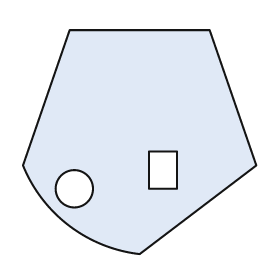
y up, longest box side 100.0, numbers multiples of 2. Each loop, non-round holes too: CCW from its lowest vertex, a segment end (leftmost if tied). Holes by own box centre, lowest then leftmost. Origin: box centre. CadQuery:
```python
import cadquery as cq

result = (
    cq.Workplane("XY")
    .moveTo(0.0, -48.0)
    .lineTo(50.0, -10.0)
    .lineTo(30.0, 48.0)
    .lineTo(-30.0, 48.0)
    .lineTo(-50.0, -10.0)
    .threePointArc((-30.0, -36.0), (0.0, -48.0))
    .close()
    .moveTo(-28.0, -20.0)
    .circle(8.0)
    .moveTo(4.0, -20.0)
    .lineTo(16.0, -20.0)
    .lineTo(16.0, -4.0)
    .lineTo(4.0, -4.0)
    .close()
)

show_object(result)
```